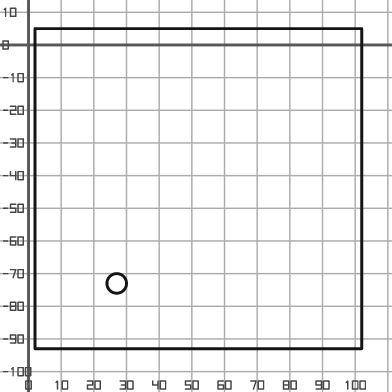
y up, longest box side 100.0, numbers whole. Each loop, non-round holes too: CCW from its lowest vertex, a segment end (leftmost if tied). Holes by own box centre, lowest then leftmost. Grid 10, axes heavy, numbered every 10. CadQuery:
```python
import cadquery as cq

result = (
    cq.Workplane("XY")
    .moveTo(2.0, -93.0)
    .lineTo(102.0, -93.0)
    .lineTo(102.0, 5.0)
    .lineTo(2.0, 5.0)
    .close()
    .moveTo(27.0, -73.0)
    .circle(3.0)
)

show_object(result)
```